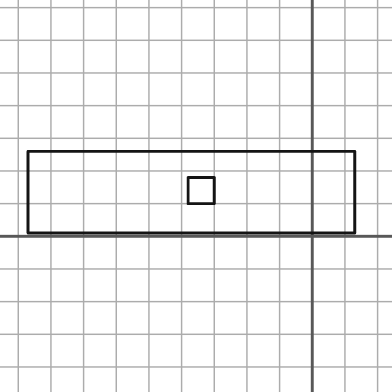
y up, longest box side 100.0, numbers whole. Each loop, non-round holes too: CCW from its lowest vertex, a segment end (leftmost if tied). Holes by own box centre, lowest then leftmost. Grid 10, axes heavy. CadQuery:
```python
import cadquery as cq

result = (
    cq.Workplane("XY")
    .moveTo(-87.0, 1.0)
    .lineTo(13.0, 1.0)
    .lineTo(13.0, 26.0)
    .lineTo(-87.0, 26.0)
    .close()
    .moveTo(-38.0, 10.0)
    .lineTo(-30.0, 10.0)
    .lineTo(-30.0, 18.0)
    .lineTo(-38.0, 18.0)
    .close()
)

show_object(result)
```